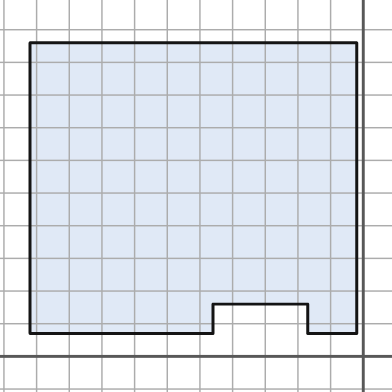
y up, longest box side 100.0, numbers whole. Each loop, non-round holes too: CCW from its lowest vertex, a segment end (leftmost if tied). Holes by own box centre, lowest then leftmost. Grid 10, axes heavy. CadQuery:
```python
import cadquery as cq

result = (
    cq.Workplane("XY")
    .moveTo(-102.0, 7.0)
    .lineTo(-46.0, 7.0)
    .lineTo(-46.0, 16.0)
    .lineTo(-17.0, 16.0)
    .lineTo(-17.0, 7.0)
    .lineTo(-2.0, 7.0)
    .lineTo(-2.0, 96.0)
    .lineTo(-102.0, 96.0)
    .close()
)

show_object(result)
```